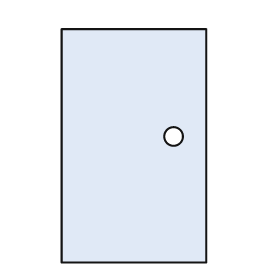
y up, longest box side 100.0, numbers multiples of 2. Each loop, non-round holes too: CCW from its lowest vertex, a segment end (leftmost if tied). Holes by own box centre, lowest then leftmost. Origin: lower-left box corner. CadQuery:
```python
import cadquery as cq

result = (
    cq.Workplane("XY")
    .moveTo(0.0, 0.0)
    .lineTo(62.0, 0.0)
    .lineTo(62.0, 100.0)
    .lineTo(0.0, 100.0)
    .close()
    .moveTo(48.0, 54.0)
    .circle(4.0)
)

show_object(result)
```